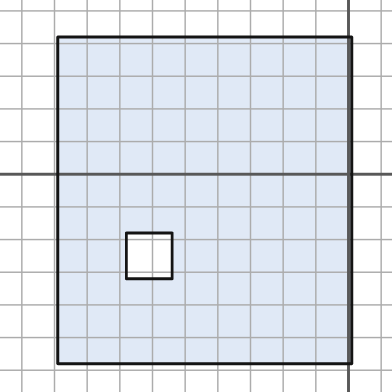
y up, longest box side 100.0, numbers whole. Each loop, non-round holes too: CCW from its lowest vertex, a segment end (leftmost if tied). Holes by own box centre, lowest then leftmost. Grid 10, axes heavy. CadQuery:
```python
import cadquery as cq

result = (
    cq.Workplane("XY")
    .moveTo(-89.0, -58.0)
    .lineTo(1.0, -58.0)
    .lineTo(1.0, 42.0)
    .lineTo(-89.0, 42.0)
    .close()
    .moveTo(-68.0, -32.0)
    .lineTo(-54.0, -32.0)
    .lineTo(-54.0, -18.0)
    .lineTo(-68.0, -18.0)
    .close()
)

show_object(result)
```